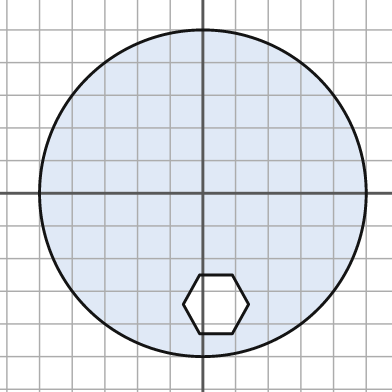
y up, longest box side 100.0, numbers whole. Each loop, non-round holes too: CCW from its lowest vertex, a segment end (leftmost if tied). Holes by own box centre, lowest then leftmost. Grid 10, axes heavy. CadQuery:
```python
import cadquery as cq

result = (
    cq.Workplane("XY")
    .moveTo(0.0, 0.0)
    .circle(50.0)
    .moveTo(-1.0, -43.0)
    .lineTo(9.0, -43.0)
    .lineTo(14.0, -34.0)
    .lineTo(9.0, -25.0)
    .lineTo(-1.0, -25.0)
    .lineTo(-6.0, -34.0)
    .close()
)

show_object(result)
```